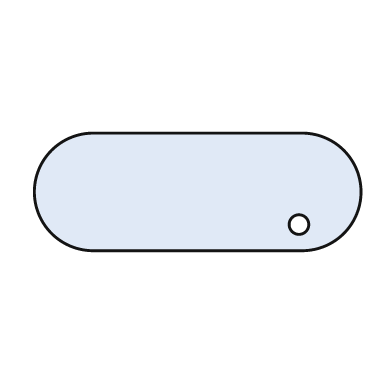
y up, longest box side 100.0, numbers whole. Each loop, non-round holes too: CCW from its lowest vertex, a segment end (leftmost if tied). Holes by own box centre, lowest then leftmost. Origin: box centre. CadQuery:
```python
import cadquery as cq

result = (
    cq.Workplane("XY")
    .moveTo(-32.0, -18.0)
    .lineTo(32.0, -18.0)
    .threePointArc((50.0, 0.0), (32.0, 18.0))
    .lineTo(-32.0, 18.0)
    .threePointArc((-50.0, 0.0), (-32.0, -18.0))
    .close()
    .moveTo(31.0, -10.0)
    .circle(3.0)
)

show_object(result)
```